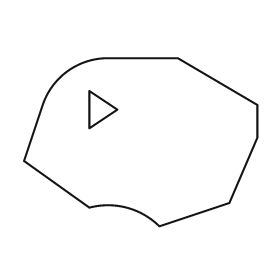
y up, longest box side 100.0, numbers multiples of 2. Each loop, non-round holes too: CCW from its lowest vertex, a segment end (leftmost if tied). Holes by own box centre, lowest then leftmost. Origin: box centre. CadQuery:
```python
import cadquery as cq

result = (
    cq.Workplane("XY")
    .moveTo(8.0, -36.0)
    .lineTo(38.0, -26.0)
    .lineTo(50.0, 2.0)
    .lineTo(50.0, 16.0)
    .lineTo(16.0, 36.0)
    .lineTo(-16.0, 36.0)
    .threePointArc((-32.0, 30.0), (-42.0, 16.0))
    .lineTo(-50.0, -8.0)
    .lineTo(-22.0, -28.0)
    .threePointArc((-6.0, -28.0), (8.0, -36.0))
    .close()
    .moveTo(-22.0, 6.0)
    .lineTo(-10.0, 14.0)
    .lineTo(-22.0, 22.0)
    .close()
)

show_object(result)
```